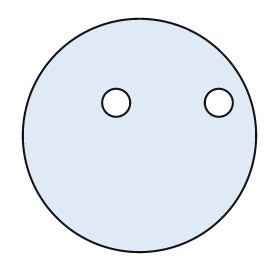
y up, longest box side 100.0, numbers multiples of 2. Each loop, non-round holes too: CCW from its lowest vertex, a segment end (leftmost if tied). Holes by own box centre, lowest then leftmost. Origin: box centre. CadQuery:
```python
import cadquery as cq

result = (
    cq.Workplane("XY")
    .moveTo(0.0, 0.0)
    .circle(50.0)
    .moveTo(-10.0, 14.0)
    .circle(6.0)
    .moveTo(34.0, 14.0)
    .circle(6.0)
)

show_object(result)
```